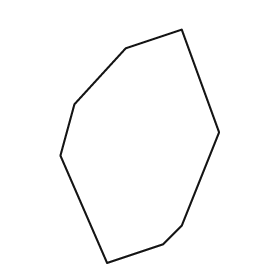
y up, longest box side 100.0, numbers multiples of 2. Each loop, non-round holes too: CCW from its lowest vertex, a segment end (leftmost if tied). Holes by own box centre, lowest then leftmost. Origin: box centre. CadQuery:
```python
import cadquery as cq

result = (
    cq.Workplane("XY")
    .moveTo(-14.0, -50.0)
    .lineTo(10.0, -42.0)
    .lineTo(18.0, -34.0)
    .lineTo(34.0, 6.0)
    .lineTo(18.0, 50.0)
    .lineTo(-6.0, 42.0)
    .lineTo(-28.0, 18.0)
    .lineTo(-34.0, -4.0)
    .close()
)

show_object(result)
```